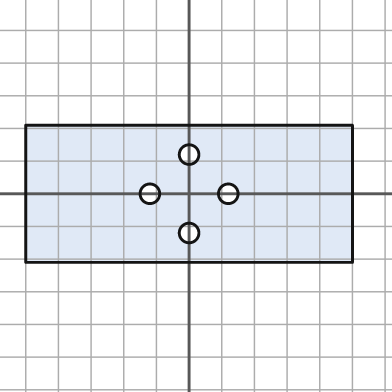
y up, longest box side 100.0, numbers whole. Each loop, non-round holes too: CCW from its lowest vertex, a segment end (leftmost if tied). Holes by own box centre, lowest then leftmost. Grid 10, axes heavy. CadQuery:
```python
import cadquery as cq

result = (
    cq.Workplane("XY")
    .moveTo(-50.0, -21.0)
    .lineTo(50.0, -21.0)
    .lineTo(50.0, 21.0)
    .lineTo(-50.0, 21.0)
    .close()
    .moveTo(0.0, -12.0)
    .circle(3.0)
    .moveTo(-12.0, 0.0)
    .circle(3.0)
    .moveTo(12.0, 0.0)
    .circle(3.0)
    .moveTo(0.0, 12.0)
    .circle(3.0)
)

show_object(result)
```